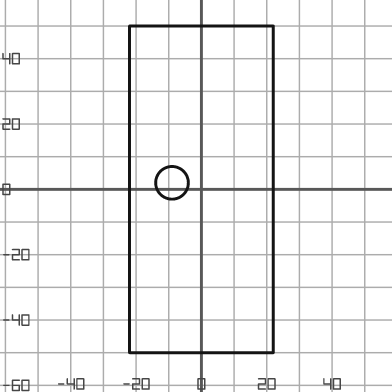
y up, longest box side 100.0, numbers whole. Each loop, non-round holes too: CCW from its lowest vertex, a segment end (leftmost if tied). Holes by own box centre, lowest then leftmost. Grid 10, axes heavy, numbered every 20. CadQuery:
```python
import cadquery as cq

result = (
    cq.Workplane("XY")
    .moveTo(-22.0, -50.0)
    .lineTo(22.0, -50.0)
    .lineTo(22.0, 50.0)
    .lineTo(-22.0, 50.0)
    .close()
    .moveTo(-9.0, 2.0)
    .circle(5.0)
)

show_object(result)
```